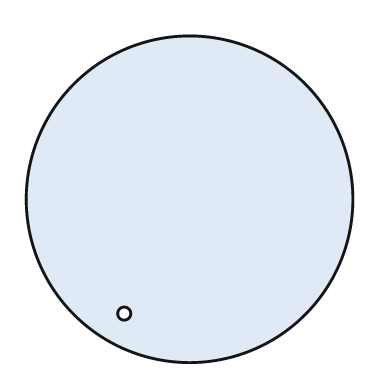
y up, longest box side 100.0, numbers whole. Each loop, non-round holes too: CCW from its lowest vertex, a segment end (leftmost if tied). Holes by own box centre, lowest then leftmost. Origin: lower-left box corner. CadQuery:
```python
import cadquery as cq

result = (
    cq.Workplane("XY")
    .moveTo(50.0, 50.0)
    .circle(50.0)
    .moveTo(30.0, 15.0)
    .circle(2.0)
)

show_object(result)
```